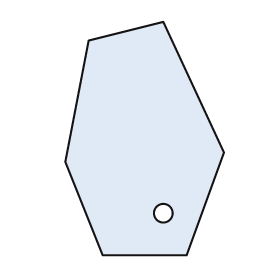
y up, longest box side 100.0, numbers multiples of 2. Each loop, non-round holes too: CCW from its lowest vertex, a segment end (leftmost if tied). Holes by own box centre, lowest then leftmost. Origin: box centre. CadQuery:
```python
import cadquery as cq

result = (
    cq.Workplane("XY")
    .moveTo(-18.0, -50.0)
    .lineTo(18.0, -50.0)
    .lineTo(34.0, -6.0)
    .lineTo(8.0, 50.0)
    .lineTo(-24.0, 42.0)
    .lineTo(-34.0, -10.0)
    .close()
    .moveTo(8.0, -32.0)
    .circle(4.0)
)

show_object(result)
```